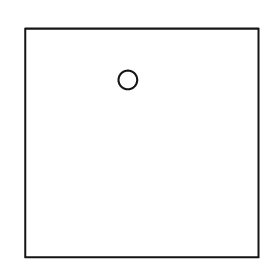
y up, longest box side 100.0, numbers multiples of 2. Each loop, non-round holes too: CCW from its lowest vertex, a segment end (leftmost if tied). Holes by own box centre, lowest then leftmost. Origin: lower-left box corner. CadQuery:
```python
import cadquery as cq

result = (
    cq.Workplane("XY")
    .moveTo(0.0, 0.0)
    .lineTo(100.0, 0.0)
    .lineTo(100.0, 98.0)
    .lineTo(0.0, 98.0)
    .close()
    .moveTo(44.0, 76.0)
    .circle(4.0)
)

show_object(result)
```